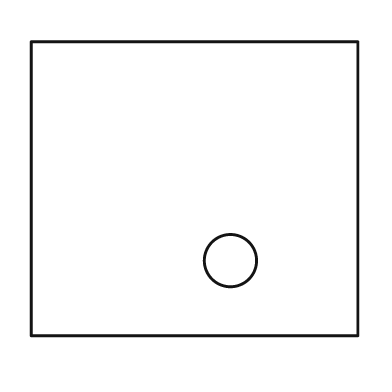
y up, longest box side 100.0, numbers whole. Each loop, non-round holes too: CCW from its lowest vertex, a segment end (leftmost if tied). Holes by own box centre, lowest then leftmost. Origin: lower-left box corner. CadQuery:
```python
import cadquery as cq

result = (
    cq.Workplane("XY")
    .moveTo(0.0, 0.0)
    .lineTo(100.0, 0.0)
    .lineTo(100.0, 90.0)
    .lineTo(0.0, 90.0)
    .close()
    .moveTo(61.0, 23.0)
    .circle(8.0)
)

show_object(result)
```